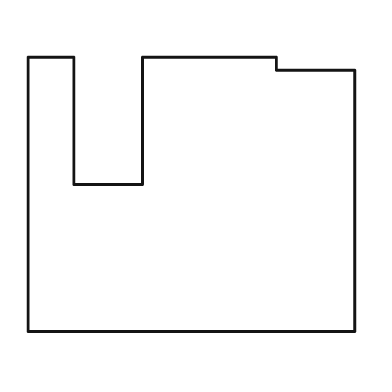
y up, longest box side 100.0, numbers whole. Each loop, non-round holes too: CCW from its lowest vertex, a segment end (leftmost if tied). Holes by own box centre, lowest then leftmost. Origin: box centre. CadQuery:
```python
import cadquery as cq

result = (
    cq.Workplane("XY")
    .moveTo(-50.0, -42.0)
    .lineTo(50.0, -42.0)
    .lineTo(50.0, 38.0)
    .lineTo(26.0, 38.0)
    .lineTo(26.0, 42.0)
    .lineTo(-15.0, 42.0)
    .lineTo(-15.0, 3.0)
    .lineTo(-36.0, 3.0)
    .lineTo(-36.0, 42.0)
    .lineTo(-50.0, 42.0)
    .close()
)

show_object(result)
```